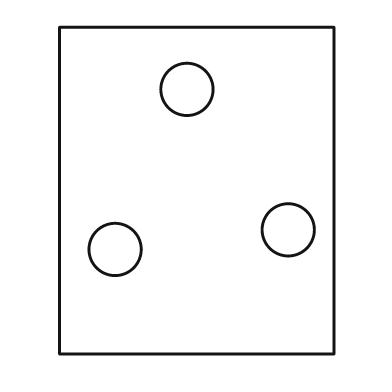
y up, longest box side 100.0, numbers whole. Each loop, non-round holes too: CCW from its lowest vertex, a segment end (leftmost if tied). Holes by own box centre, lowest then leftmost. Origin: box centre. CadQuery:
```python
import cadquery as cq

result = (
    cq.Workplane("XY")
    .moveTo(-42.0, -50.0)
    .lineTo(42.0, -50.0)
    .lineTo(42.0, 50.0)
    .lineTo(-42.0, 50.0)
    .close()
    .moveTo(-25.0, -18.0)
    .circle(8.0)
    .moveTo(28.0, -12.0)
    .circle(8.0)
    .moveTo(-3.0, 31.0)
    .circle(8.0)
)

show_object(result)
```